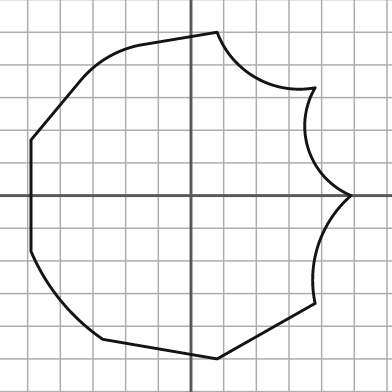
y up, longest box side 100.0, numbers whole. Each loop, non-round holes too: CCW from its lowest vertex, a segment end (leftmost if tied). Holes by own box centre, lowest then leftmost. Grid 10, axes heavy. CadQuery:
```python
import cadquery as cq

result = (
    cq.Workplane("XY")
    .moveTo(8.0, -50.0)
    .lineTo(38.0, -33.0)
    .threePointArc((39.0, -15.0), (49.0, 0.0))
    .threePointArc((36.0, 14.0), (38.0, 33.0))
    .threePointArc((20.0, 36.0), (8.0, 50.0))
    .lineTo(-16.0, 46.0)
    .threePointArc((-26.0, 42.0), (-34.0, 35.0))
    .lineTo(-49.0, 17.0)
    .lineTo(-49.0, -17.0)
    .threePointArc((-40.0, -32.0), (-27.0, -44.0))
    .close()
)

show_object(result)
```